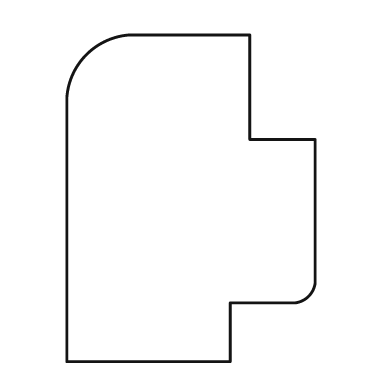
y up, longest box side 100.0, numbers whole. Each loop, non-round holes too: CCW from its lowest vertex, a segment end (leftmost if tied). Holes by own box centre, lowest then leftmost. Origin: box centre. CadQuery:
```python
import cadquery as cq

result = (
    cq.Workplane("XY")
    .moveTo(-38.0, -50.0)
    .lineTo(12.0, -50.0)
    .lineTo(12.0, -32.0)
    .lineTo(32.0, -32.0)
    .threePointArc((36.0, -30.0), (38.0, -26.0))
    .lineTo(38.0, 18.0)
    .lineTo(18.0, 18.0)
    .lineTo(18.0, 50.0)
    .lineTo(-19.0, 50.0)
    .threePointArc((-32.0, 44.0), (-38.0, 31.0))
    .close()
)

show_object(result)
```